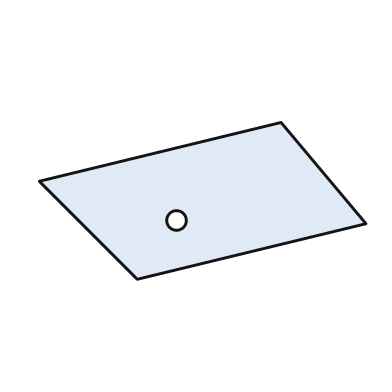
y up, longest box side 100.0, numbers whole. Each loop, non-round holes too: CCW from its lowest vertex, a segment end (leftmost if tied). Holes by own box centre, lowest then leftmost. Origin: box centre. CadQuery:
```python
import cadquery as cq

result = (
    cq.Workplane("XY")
    .moveTo(-20.0, -24.0)
    .lineTo(50.0, -7.0)
    .lineTo(24.0, 24.0)
    .lineTo(-50.0, 6.0)
    .close()
    .moveTo(-8.0, -6.0)
    .circle(3.0)
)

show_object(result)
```